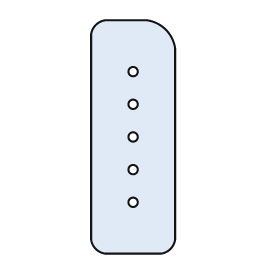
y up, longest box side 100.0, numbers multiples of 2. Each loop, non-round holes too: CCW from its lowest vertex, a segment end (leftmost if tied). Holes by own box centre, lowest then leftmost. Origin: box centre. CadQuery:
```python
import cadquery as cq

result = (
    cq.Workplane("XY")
    .moveTo(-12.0, -50.0)
    .lineTo(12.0, -50.0)
    .threePointArc((16.0, -48.0), (18.0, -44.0))
    .lineTo(18.0, 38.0)
    .threePointArc((14.0, 46.0), (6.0, 50.0))
    .lineTo(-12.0, 50.0)
    .threePointArc((-16.0, 48.0), (-18.0, 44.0))
    .lineTo(-18.0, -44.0)
    .threePointArc((-16.0, -48.0), (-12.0, -50.0))
    .close()
    .moveTo(0.0, -28.0)
    .circle(2.0)
    .moveTo(0.0, -14.0)
    .circle(2.0)
    .moveTo(0.0, 0.0)
    .circle(2.0)
    .moveTo(0.0, 14.0)
    .circle(2.0)
    .moveTo(0.0, 28.0)
    .circle(2.0)
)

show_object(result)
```